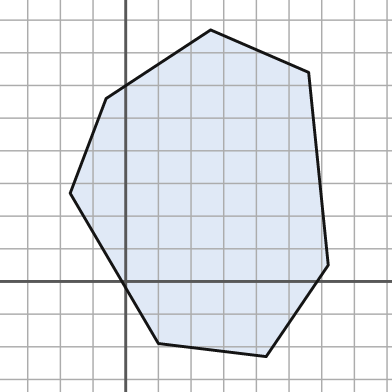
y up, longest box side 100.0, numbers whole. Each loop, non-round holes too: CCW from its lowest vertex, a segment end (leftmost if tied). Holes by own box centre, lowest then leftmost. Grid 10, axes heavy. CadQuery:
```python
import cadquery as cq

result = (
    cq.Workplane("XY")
    .moveTo(43.0, -23.0)
    .lineTo(62.0, 5.0)
    .lineTo(56.0, 64.0)
    .lineTo(26.0, 77.0)
    .lineTo(-6.0, 56.0)
    .lineTo(-17.0, 27.0)
    .lineTo(10.0, -19.0)
    .close()
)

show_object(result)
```